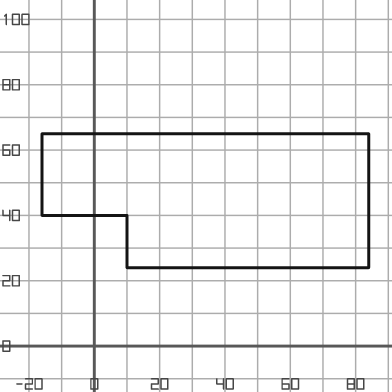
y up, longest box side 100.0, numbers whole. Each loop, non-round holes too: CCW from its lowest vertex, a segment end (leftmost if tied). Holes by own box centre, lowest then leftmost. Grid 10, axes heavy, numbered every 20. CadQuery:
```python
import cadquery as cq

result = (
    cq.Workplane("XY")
    .moveTo(10.0, 24.0)
    .lineTo(84.0, 24.0)
    .lineTo(84.0, 65.0)
    .lineTo(-16.0, 65.0)
    .lineTo(-16.0, 40.0)
    .lineTo(10.0, 40.0)
    .close()
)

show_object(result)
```